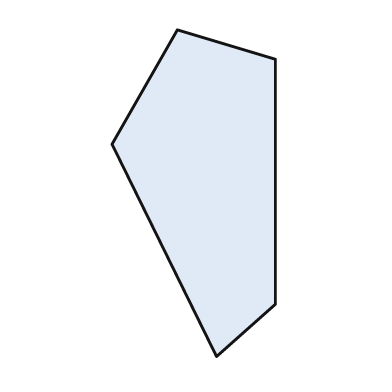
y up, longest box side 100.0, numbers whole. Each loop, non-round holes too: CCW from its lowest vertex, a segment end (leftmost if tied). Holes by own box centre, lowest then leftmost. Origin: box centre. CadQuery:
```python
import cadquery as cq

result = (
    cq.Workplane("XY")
    .moveTo(7.0, -50.0)
    .lineTo(25.0, -34.0)
    .lineTo(25.0, 41.0)
    .lineTo(-5.0, 50.0)
    .lineTo(-25.0, 15.0)
    .close()
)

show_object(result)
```